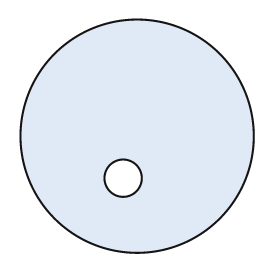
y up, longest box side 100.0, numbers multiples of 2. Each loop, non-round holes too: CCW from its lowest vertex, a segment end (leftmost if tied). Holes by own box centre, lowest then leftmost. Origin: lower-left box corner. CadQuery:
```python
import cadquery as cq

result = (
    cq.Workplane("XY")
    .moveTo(50.0, 50.0)
    .circle(50.0)
    .moveTo(44.0, 32.0)
    .circle(8.0)
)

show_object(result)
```